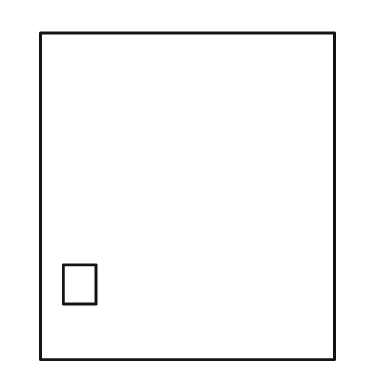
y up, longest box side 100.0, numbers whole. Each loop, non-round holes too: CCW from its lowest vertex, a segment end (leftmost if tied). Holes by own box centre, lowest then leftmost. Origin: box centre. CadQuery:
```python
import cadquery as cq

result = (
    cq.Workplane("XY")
    .moveTo(-45.0, -50.0)
    .lineTo(45.0, -50.0)
    .lineTo(45.0, 50.0)
    .lineTo(-45.0, 50.0)
    .close()
    .moveTo(-38.0, -33.0)
    .lineTo(-28.0, -33.0)
    .lineTo(-28.0, -21.0)
    .lineTo(-38.0, -21.0)
    .close()
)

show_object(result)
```